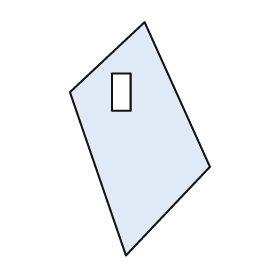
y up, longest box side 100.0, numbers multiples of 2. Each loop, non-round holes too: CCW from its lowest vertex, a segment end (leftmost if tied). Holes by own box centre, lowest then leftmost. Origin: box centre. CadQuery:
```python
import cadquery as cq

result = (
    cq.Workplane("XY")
    .moveTo(-6.0, -50.0)
    .lineTo(30.0, -12.0)
    .lineTo(2.0, 50.0)
    .lineTo(-30.0, 20.0)
    .close()
    .moveTo(-12.0, 12.0)
    .lineTo(-4.0, 12.0)
    .lineTo(-4.0, 28.0)
    .lineTo(-12.0, 28.0)
    .close()
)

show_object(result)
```